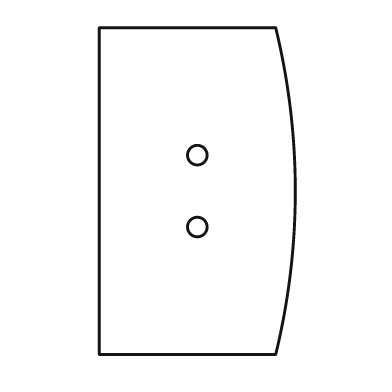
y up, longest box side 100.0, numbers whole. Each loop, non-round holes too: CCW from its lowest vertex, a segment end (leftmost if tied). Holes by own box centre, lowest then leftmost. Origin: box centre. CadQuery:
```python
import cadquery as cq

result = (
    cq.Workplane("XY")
    .moveTo(-30.0, -50.0)
    .lineTo(24.0, -50.0)
    .threePointArc((30.0, 0.0), (24.0, 50.0))
    .lineTo(-30.0, 50.0)
    .close()
    .moveTo(0.0, -11.0)
    .circle(3.0)
    .moveTo(0.0, 11.0)
    .circle(3.0)
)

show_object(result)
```